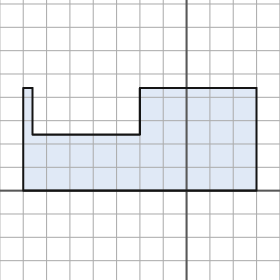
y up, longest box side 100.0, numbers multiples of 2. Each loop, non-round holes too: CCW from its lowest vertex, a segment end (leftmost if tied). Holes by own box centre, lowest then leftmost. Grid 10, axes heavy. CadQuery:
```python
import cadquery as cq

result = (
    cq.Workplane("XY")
    .moveTo(-70.0, 0.0)
    .lineTo(30.0, 0.0)
    .lineTo(30.0, 44.0)
    .lineTo(-20.0, 44.0)
    .lineTo(-20.0, 24.0)
    .lineTo(-66.0, 24.0)
    .lineTo(-66.0, 44.0)
    .lineTo(-70.0, 44.0)
    .close()
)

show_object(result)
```